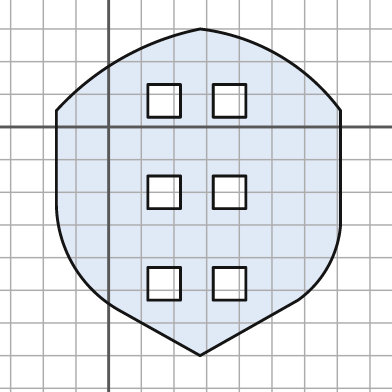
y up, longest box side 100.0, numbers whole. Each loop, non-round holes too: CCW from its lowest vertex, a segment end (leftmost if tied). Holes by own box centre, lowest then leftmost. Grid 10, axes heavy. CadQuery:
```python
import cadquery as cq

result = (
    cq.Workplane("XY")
    .moveTo(28.0, -70.0)
    .lineTo(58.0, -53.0)
    .threePointArc((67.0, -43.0), (71.0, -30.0))
    .lineTo(71.0, 5.0)
    .threePointArc((52.0, 22.0), (28.0, 30.0))
    .threePointArc((4.0, 21.0), (-16.0, 5.0))
    .lineTo(-16.0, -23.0)
    .threePointArc((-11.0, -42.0), (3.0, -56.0))
    .close()
    .moveTo(12.0, -53.0)
    .lineTo(22.0, -53.0)
    .lineTo(22.0, -43.0)
    .lineTo(12.0, -43.0)
    .close()
    .moveTo(32.0, -53.0)
    .lineTo(42.0, -53.0)
    .lineTo(42.0, -43.0)
    .lineTo(32.0, -43.0)
    .close()
    .moveTo(12.0, -25.0)
    .lineTo(22.0, -25.0)
    .lineTo(22.0, -15.0)
    .lineTo(12.0, -15.0)
    .close()
    .moveTo(32.0, -25.0)
    .lineTo(42.0, -25.0)
    .lineTo(42.0, -15.0)
    .lineTo(32.0, -15.0)
    .close()
    .moveTo(12.0, 3.0)
    .lineTo(22.0, 3.0)
    .lineTo(22.0, 13.0)
    .lineTo(12.0, 13.0)
    .close()
    .moveTo(32.0, 3.0)
    .lineTo(42.0, 3.0)
    .lineTo(42.0, 13.0)
    .lineTo(32.0, 13.0)
    .close()
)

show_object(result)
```